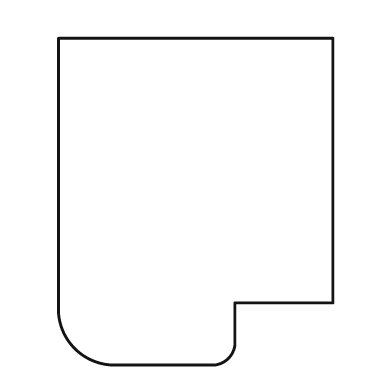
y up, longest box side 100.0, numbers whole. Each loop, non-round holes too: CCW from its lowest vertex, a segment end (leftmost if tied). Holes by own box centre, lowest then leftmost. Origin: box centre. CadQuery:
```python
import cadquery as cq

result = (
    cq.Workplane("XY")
    .moveTo(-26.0, -50.0)
    .lineTo(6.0, -50.0)
    .threePointArc((10.0, -48.0), (12.0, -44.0))
    .lineTo(12.0, -31.0)
    .lineTo(42.0, -31.0)
    .lineTo(42.0, 50.0)
    .lineTo(-42.0, 50.0)
    .lineTo(-42.0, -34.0)
    .threePointArc((-37.0, -45.0), (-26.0, -50.0))
    .close()
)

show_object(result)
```